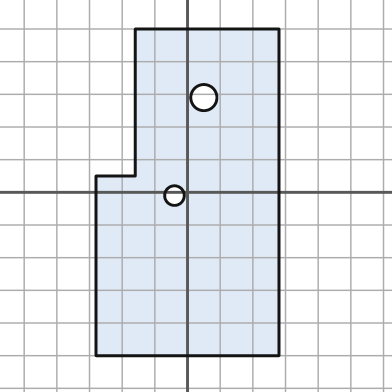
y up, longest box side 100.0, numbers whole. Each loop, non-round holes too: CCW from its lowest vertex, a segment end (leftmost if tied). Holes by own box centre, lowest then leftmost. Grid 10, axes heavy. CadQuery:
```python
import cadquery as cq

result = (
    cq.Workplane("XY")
    .moveTo(-28.0, -50.0)
    .lineTo(28.0, -50.0)
    .lineTo(28.0, 50.0)
    .lineTo(-16.0, 50.0)
    .lineTo(-16.0, 5.0)
    .lineTo(-28.0, 5.0)
    .close()
    .moveTo(-4.0, -1.0)
    .circle(3.0)
    .moveTo(5.0, 29.0)
    .circle(4.0)
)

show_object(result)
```